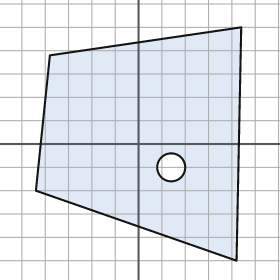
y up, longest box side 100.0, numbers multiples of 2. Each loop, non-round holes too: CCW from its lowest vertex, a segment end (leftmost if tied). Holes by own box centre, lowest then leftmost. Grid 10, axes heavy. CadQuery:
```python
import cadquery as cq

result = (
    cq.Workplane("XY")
    .moveTo(42.0, -50.0)
    .lineTo(44.0, 50.0)
    .lineTo(-38.0, 38.0)
    .lineTo(-44.0, -20.0)
    .close()
    .moveTo(14.0, -10.0)
    .circle(6.0)
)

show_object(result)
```